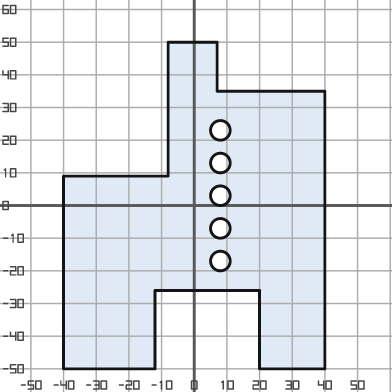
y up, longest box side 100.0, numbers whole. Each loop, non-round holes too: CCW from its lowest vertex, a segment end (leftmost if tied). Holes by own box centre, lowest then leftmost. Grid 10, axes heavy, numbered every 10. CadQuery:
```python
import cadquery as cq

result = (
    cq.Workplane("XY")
    .moveTo(-40.0, -50.0)
    .lineTo(-12.0, -50.0)
    .lineTo(-12.0, -26.0)
    .lineTo(20.0, -26.0)
    .lineTo(20.0, -50.0)
    .lineTo(40.0, -50.0)
    .lineTo(40.0, 35.0)
    .lineTo(7.0, 35.0)
    .lineTo(7.0, 50.0)
    .lineTo(-8.0, 50.0)
    .lineTo(-8.0, 9.0)
    .lineTo(-40.0, 9.0)
    .close()
    .moveTo(8.0, -17.0)
    .circle(3.0)
    .moveTo(8.0, -7.0)
    .circle(3.0)
    .moveTo(8.0, 3.0)
    .circle(3.0)
    .moveTo(8.0, 13.0)
    .circle(3.0)
    .moveTo(8.0, 23.0)
    .circle(3.0)
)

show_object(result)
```